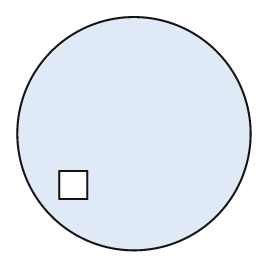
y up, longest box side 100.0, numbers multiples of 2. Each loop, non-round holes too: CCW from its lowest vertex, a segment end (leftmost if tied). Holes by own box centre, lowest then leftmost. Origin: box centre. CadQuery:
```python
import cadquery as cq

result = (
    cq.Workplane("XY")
    .moveTo(0.0, 0.0)
    .circle(50.0)
    .moveTo(-32.0, -28.0)
    .lineTo(-20.0, -28.0)
    .lineTo(-20.0, -16.0)
    .lineTo(-32.0, -16.0)
    .close()
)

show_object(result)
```